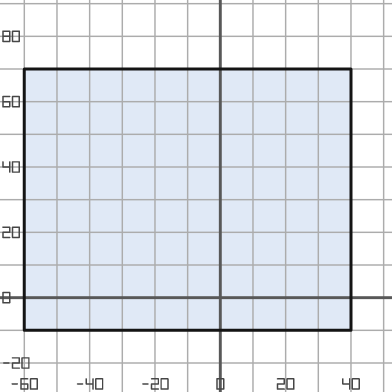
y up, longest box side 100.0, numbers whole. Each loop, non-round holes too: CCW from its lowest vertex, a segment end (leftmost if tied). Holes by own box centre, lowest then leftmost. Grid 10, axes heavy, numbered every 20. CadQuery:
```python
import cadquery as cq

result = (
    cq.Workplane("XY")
    .moveTo(-60.0, -10.0)
    .lineTo(40.0, -10.0)
    .lineTo(40.0, 70.0)
    .lineTo(-60.0, 70.0)
    .close()
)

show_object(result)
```